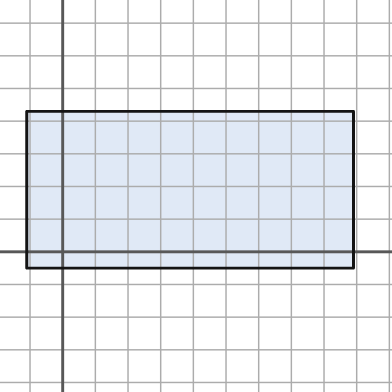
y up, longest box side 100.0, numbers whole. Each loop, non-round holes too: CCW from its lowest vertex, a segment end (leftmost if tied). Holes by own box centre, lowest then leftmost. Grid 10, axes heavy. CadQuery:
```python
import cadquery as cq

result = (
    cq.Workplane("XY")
    .moveTo(-11.0, -5.0)
    .lineTo(89.0, -5.0)
    .lineTo(89.0, 43.0)
    .lineTo(-11.0, 43.0)
    .close()
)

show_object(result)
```